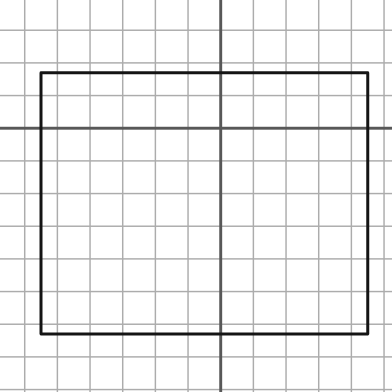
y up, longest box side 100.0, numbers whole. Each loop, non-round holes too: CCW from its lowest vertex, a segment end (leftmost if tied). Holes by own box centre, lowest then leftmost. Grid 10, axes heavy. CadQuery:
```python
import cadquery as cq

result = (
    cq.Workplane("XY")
    .moveTo(-55.0, -63.0)
    .lineTo(45.0, -63.0)
    .lineTo(45.0, 17.0)
    .lineTo(-55.0, 17.0)
    .close()
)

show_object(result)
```